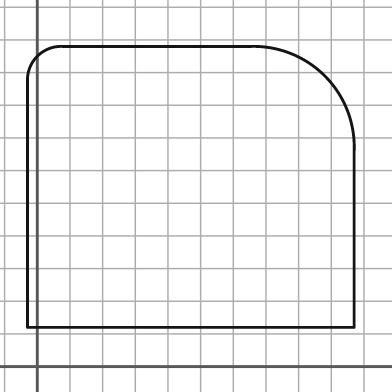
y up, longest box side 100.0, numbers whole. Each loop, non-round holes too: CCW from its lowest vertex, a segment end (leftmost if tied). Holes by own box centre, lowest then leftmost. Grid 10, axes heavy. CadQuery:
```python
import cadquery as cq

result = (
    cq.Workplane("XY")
    .moveTo(-3.0, 12.0)
    .lineTo(97.0, 12.0)
    .lineTo(97.0, 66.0)
    .threePointArc((88.0, 89.0), (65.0, 98.0))
    .lineTo(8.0, 98.0)
    .threePointArc((0.0, 95.0), (-3.0, 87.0))
    .close()
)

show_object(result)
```